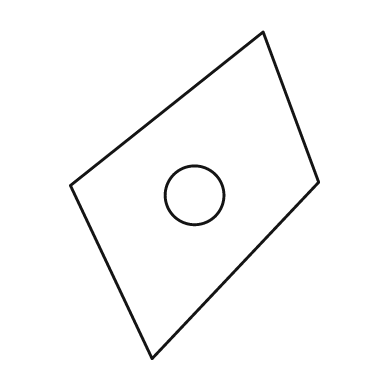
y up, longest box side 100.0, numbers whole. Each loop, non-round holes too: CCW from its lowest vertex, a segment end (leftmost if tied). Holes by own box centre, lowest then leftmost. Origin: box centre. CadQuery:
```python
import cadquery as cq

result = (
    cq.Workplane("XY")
    .moveTo(-13.0, -50.0)
    .lineTo(38.0, 4.0)
    .lineTo(21.0, 50.0)
    .lineTo(-38.0, 3.0)
    .close()
    .moveTo(0.0, 0.0)
    .circle(9.0)
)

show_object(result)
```